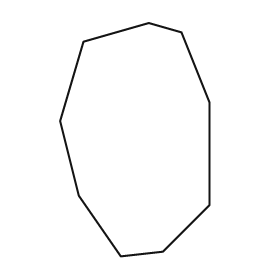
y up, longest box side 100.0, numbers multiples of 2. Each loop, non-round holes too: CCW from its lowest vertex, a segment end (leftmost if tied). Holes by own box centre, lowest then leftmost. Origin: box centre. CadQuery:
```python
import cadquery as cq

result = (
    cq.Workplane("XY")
    .moveTo(-6.0, -50.0)
    .lineTo(12.0, -48.0)
    .lineTo(32.0, -28.0)
    .lineTo(32.0, 16.0)
    .lineTo(20.0, 46.0)
    .lineTo(6.0, 50.0)
    .lineTo(-22.0, 42.0)
    .lineTo(-32.0, 8.0)
    .lineTo(-24.0, -24.0)
    .close()
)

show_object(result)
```